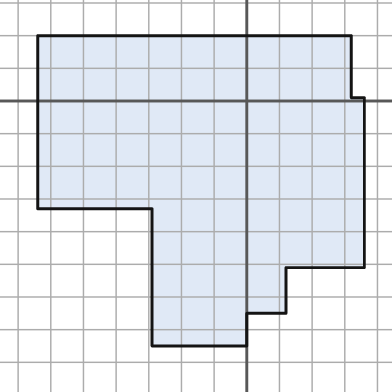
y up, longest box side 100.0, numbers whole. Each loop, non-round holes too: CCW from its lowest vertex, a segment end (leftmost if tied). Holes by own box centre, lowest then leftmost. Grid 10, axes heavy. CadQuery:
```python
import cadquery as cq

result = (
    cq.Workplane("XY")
    .moveTo(-29.0, -75.0)
    .lineTo(0.0, -75.0)
    .lineTo(0.0, -65.0)
    .lineTo(12.0, -65.0)
    .lineTo(12.0, -51.0)
    .lineTo(36.0, -51.0)
    .lineTo(36.0, 1.0)
    .lineTo(32.0, 1.0)
    .lineTo(32.0, 20.0)
    .lineTo(-64.0, 20.0)
    .lineTo(-64.0, -33.0)
    .lineTo(-29.0, -33.0)
    .close()
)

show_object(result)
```